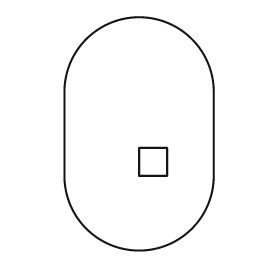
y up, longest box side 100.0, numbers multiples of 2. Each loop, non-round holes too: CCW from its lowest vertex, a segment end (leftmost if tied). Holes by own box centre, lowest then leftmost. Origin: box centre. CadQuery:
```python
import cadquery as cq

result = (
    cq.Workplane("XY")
    .moveTo(-32.0, -18.0)
    .threePointArc((0.0, -50.0), (32.0, -18.0))
    .lineTo(32.0, 18.0)
    .threePointArc((0.0, 50.0), (-32.0, 18.0))
    .close()
    .moveTo(0.0, -18.0)
    .lineTo(12.0, -18.0)
    .lineTo(12.0, -6.0)
    .lineTo(0.0, -6.0)
    .close()
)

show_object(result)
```